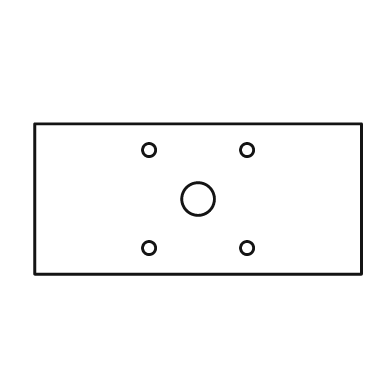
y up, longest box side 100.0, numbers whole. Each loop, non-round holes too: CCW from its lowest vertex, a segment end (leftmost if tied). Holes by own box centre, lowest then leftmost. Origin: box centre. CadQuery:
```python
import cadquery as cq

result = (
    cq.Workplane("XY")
    .moveTo(-50.0, -23.0)
    .lineTo(50.0, -23.0)
    .lineTo(50.0, 23.0)
    .lineTo(-50.0, 23.0)
    .close()
    .moveTo(-15.0, -15.0)
    .circle(2.0)
    .moveTo(15.0, -15.0)
    .circle(2.0)
    .moveTo(0.0, 0.0)
    .circle(5.0)
    .moveTo(-15.0, 15.0)
    .circle(2.0)
    .moveTo(15.0, 15.0)
    .circle(2.0)
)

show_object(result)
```